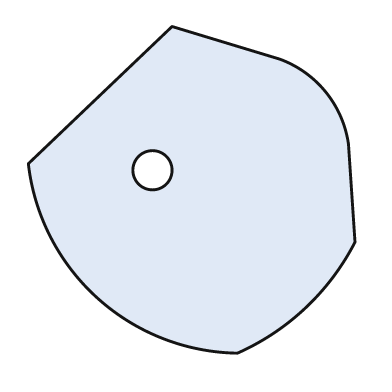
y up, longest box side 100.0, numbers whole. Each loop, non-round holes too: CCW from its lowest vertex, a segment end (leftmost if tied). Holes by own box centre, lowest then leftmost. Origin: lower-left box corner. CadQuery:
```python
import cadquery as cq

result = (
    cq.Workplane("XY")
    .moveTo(64.0, 0.0)
    .threePointArc((85.0, 14.0), (100.0, 34.0))
    .lineTo(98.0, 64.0)
    .threePointArc((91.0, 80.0), (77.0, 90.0))
    .lineTo(44.0, 100.0)
    .lineTo(0.0, 58.0)
    .threePointArc((21.0, 17.0), (64.0, 0.0))
    .close()
    .moveTo(38.0, 56.0)
    .circle(6.0)
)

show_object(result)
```